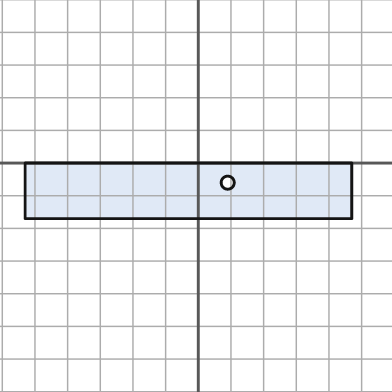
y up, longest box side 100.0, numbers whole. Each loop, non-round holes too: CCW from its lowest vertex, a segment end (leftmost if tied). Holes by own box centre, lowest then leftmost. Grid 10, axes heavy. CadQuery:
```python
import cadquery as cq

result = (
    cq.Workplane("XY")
    .moveTo(-53.0, -17.0)
    .lineTo(47.0, -17.0)
    .lineTo(47.0, 0.0)
    .lineTo(-53.0, 0.0)
    .close()
    .moveTo(9.0, -6.0)
    .circle(2.0)
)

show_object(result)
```